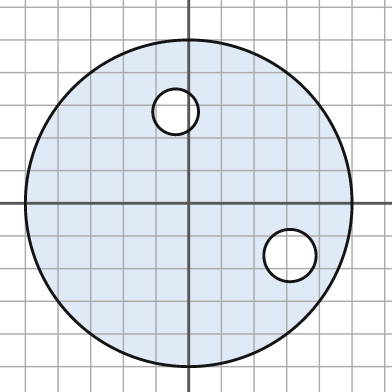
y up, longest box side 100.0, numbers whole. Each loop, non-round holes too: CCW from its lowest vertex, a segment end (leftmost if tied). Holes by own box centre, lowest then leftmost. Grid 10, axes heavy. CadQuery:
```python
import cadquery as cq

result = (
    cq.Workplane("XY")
    .moveTo(0.0, 0.0)
    .circle(50.0)
    .moveTo(31.0, -16.0)
    .circle(8.0)
    .moveTo(-4.0, 28.0)
    .circle(7.0)
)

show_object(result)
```